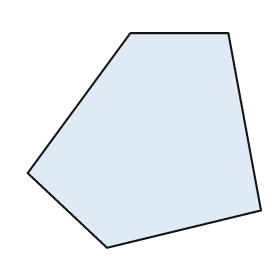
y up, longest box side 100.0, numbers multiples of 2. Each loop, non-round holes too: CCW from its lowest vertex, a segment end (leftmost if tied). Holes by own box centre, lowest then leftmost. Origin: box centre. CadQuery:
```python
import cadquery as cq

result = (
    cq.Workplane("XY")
    .moveTo(-16.0, -46.0)
    .lineTo(50.0, -30.0)
    .lineTo(36.0, 46.0)
    .lineTo(-6.0, 46.0)
    .lineTo(-50.0, -14.0)
    .close()
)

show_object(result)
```